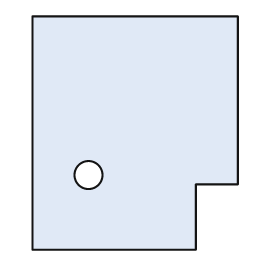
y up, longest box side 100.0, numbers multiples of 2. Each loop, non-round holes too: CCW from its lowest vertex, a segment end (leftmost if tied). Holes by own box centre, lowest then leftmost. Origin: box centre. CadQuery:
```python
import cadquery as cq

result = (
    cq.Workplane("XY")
    .moveTo(-44.0, -50.0)
    .lineTo(26.0, -50.0)
    .lineTo(26.0, -22.0)
    .lineTo(44.0, -22.0)
    .lineTo(44.0, 50.0)
    .lineTo(-44.0, 50.0)
    .close()
    .moveTo(-20.0, -18.0)
    .circle(6.0)
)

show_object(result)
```